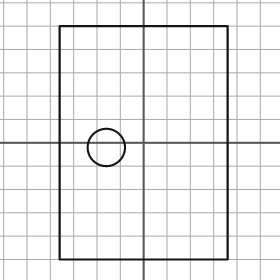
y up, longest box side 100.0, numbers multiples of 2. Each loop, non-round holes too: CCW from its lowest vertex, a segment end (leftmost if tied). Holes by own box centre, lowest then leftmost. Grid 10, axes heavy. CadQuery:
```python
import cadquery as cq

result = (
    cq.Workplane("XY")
    .moveTo(-36.0, -50.0)
    .lineTo(36.0, -50.0)
    .lineTo(36.0, 50.0)
    .lineTo(-36.0, 50.0)
    .close()
    .moveTo(-16.0, -2.0)
    .circle(8.0)
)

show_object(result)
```